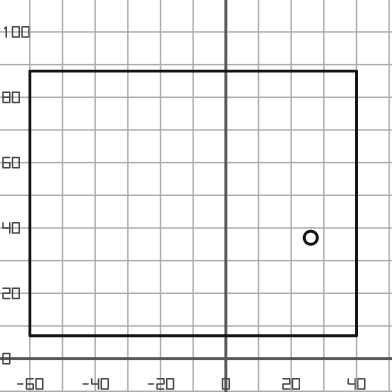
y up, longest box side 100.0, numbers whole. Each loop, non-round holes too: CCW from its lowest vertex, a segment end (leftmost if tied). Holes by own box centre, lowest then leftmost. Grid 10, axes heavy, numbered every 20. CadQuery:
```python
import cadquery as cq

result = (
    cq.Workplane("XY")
    .moveTo(-60.0, 7.0)
    .lineTo(40.0, 7.0)
    .lineTo(40.0, 88.0)
    .lineTo(-60.0, 88.0)
    .close()
    .moveTo(26.0, 37.0)
    .circle(2.0)
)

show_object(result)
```